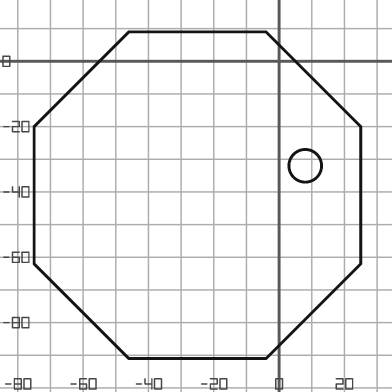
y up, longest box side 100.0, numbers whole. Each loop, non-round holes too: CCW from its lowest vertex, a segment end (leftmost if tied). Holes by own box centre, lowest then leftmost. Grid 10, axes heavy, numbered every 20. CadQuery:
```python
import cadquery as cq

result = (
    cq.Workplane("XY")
    .moveTo(-46.0, -91.0)
    .lineTo(-4.0, -91.0)
    .lineTo(25.0, -62.0)
    .lineTo(25.0, -20.0)
    .lineTo(-4.0, 9.0)
    .lineTo(-46.0, 9.0)
    .lineTo(-75.0, -20.0)
    .lineTo(-75.0, -62.0)
    .close()
    .moveTo(8.0, -32.0)
    .circle(5.0)
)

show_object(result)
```